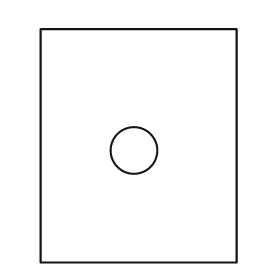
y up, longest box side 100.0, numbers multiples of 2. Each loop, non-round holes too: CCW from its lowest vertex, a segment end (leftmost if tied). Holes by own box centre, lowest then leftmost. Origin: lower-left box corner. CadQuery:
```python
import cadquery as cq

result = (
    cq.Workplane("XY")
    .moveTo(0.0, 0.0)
    .lineTo(84.0, 0.0)
    .lineTo(84.0, 100.0)
    .lineTo(0.0, 100.0)
    .close()
    .moveTo(40.0, 48.0)
    .circle(10.0)
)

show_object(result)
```